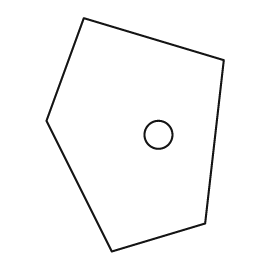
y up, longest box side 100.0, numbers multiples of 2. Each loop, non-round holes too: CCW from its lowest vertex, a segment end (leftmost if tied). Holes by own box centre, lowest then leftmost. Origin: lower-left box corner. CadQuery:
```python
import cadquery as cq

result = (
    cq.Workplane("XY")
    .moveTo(28.0, 0.0)
    .lineTo(68.0, 12.0)
    .lineTo(76.0, 82.0)
    .lineTo(16.0, 100.0)
    .lineTo(0.0, 56.0)
    .close()
    .moveTo(48.0, 50.0)
    .circle(6.0)
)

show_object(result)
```